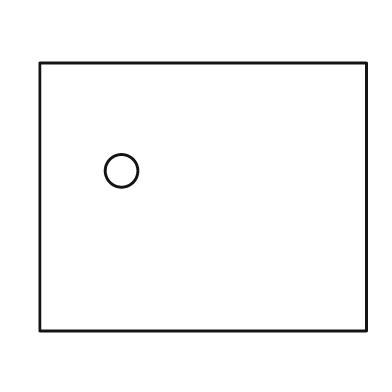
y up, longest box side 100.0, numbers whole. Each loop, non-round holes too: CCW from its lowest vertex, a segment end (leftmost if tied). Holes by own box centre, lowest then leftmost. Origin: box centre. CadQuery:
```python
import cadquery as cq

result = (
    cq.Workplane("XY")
    .moveTo(-50.0, -41.0)
    .lineTo(50.0, -41.0)
    .lineTo(50.0, 41.0)
    .lineTo(-50.0, 41.0)
    .close()
    .moveTo(-25.0, 8.0)
    .circle(5.0)
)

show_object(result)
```